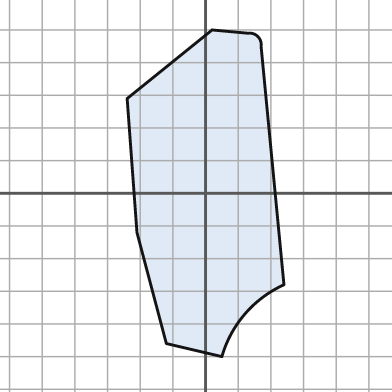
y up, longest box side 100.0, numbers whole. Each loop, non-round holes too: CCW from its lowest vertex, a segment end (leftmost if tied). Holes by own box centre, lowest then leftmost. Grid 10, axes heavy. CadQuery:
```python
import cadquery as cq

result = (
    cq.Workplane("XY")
    .moveTo(5.0, -50.0)
    .threePointArc((12.0, -37.0), (24.0, -28.0))
    .lineTo(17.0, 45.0)
    .threePointArc((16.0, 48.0), (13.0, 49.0))
    .lineTo(2.0, 50.0)
    .lineTo(-24.0, 29.0)
    .lineTo(-21.0, -12.0)
    .lineTo(-12.0, -46.0)
    .close()
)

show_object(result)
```